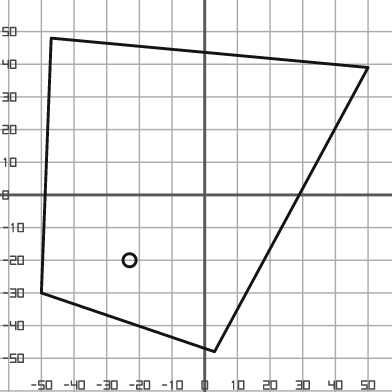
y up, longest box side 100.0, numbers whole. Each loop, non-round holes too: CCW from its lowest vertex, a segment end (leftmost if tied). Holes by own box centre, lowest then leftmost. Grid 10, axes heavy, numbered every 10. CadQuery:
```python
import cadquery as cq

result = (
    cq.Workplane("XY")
    .moveTo(3.0, -48.0)
    .lineTo(50.0, 39.0)
    .lineTo(-47.0, 48.0)
    .lineTo(-50.0, -30.0)
    .close()
    .moveTo(-23.0, -20.0)
    .circle(2.0)
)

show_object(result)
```